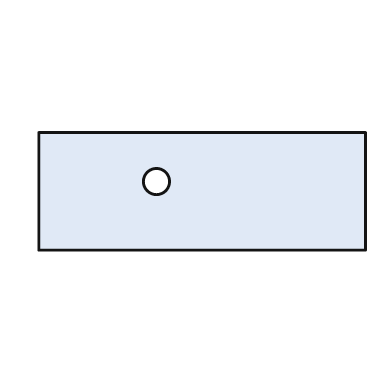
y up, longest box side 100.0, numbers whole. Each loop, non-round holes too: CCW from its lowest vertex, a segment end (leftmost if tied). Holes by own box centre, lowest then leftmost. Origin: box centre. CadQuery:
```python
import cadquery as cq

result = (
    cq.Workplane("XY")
    .moveTo(-50.0, -18.0)
    .lineTo(50.0, -18.0)
    .lineTo(50.0, 18.0)
    .lineTo(-50.0, 18.0)
    .close()
    .moveTo(-14.0, 3.0)
    .circle(4.0)
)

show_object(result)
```